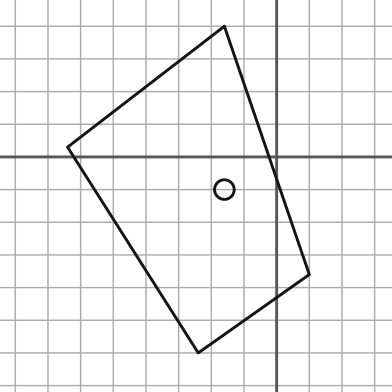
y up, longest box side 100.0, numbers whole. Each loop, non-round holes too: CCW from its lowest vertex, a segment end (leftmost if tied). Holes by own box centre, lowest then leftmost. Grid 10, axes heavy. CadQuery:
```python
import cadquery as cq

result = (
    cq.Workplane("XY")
    .moveTo(-24.0, -60.0)
    .lineTo(10.0, -36.0)
    .lineTo(-16.0, 40.0)
    .lineTo(-64.0, 3.0)
    .close()
    .moveTo(-16.0, -10.0)
    .circle(3.0)
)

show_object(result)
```